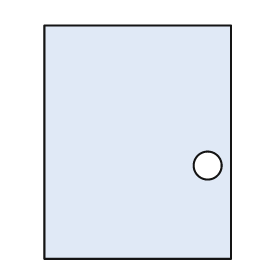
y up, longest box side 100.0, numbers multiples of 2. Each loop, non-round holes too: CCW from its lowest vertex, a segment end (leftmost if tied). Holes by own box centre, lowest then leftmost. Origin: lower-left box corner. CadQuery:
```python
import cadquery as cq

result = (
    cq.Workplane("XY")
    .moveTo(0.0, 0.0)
    .lineTo(80.0, 0.0)
    .lineTo(80.0, 100.0)
    .lineTo(0.0, 100.0)
    .close()
    .moveTo(70.0, 40.0)
    .circle(6.0)
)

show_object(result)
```